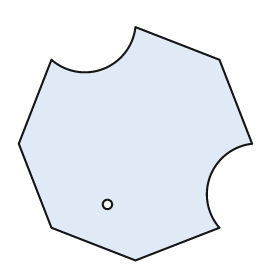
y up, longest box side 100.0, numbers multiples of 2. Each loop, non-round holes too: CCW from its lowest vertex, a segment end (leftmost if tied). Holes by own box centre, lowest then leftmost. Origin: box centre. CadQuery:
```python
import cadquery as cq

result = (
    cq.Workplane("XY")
    .moveTo(0.0, -50.0)
    .lineTo(36.0, -36.0)
    .threePointArc((32.0, -14.0), (50.0, 0.0))
    .lineTo(36.0, 36.0)
    .lineTo(0.0, 50.0)
    .threePointArc((-14.0, 32.0), (-36.0, 36.0))
    .lineTo(-50.0, 0.0)
    .lineTo(-36.0, -36.0)
    .close()
    .moveTo(-12.0, -26.0)
    .circle(2.0)
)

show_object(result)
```